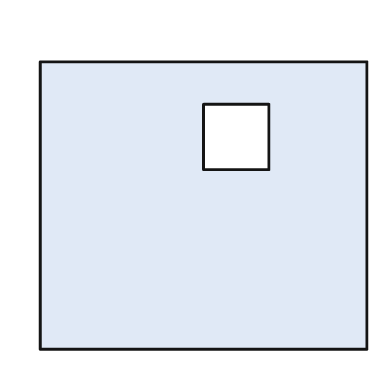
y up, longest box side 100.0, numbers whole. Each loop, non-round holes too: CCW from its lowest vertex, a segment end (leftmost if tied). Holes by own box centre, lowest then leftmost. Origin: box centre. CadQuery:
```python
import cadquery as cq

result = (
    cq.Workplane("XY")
    .moveTo(-50.0, -44.0)
    .lineTo(50.0, -44.0)
    .lineTo(50.0, 44.0)
    .lineTo(-50.0, 44.0)
    .close()
    .moveTo(0.0, 11.0)
    .lineTo(20.0, 11.0)
    .lineTo(20.0, 31.0)
    .lineTo(0.0, 31.0)
    .close()
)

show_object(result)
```